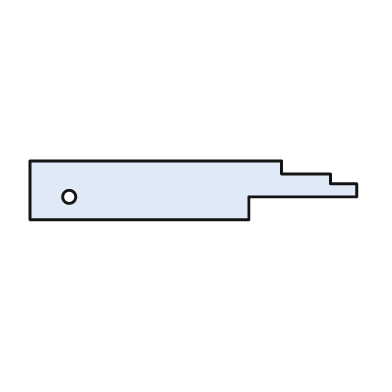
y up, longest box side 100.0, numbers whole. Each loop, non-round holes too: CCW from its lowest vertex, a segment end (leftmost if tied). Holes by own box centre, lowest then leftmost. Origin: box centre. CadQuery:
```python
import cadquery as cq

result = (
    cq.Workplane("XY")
    .moveTo(-50.0, -9.0)
    .lineTo(17.0, -9.0)
    .lineTo(17.0, -2.0)
    .lineTo(50.0, -2.0)
    .lineTo(50.0, 2.0)
    .lineTo(42.0, 2.0)
    .lineTo(42.0, 5.0)
    .lineTo(27.0, 5.0)
    .lineTo(27.0, 9.0)
    .lineTo(-50.0, 9.0)
    .close()
    .moveTo(-38.0, -2.0)
    .circle(2.0)
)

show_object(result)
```